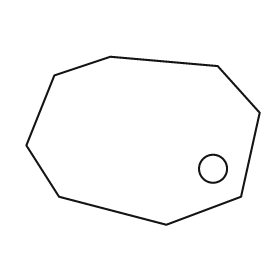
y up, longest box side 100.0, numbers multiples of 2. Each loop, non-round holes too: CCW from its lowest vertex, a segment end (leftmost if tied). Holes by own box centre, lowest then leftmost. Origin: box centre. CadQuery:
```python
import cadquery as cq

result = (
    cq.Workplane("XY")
    .moveTo(10.0, -36.0)
    .lineTo(42.0, -24.0)
    .lineTo(50.0, 12.0)
    .lineTo(32.0, 32.0)
    .lineTo(-14.0, 36.0)
    .lineTo(-38.0, 28.0)
    .lineTo(-50.0, -2.0)
    .lineTo(-36.0, -24.0)
    .close()
    .moveTo(30.0, -12.0)
    .circle(6.0)
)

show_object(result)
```